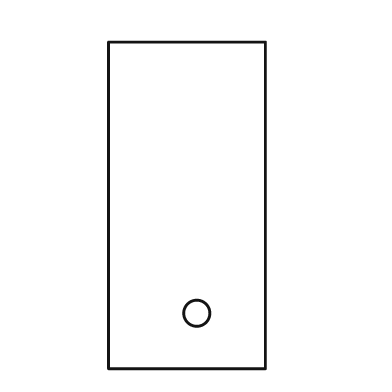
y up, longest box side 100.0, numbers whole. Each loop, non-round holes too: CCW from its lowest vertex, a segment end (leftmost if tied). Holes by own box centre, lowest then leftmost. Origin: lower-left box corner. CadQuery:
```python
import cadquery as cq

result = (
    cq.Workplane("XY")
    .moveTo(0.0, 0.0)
    .lineTo(48.0, 0.0)
    .lineTo(48.0, 100.0)
    .lineTo(0.0, 100.0)
    .close()
    .moveTo(27.0, 17.0)
    .circle(4.0)
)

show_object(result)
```